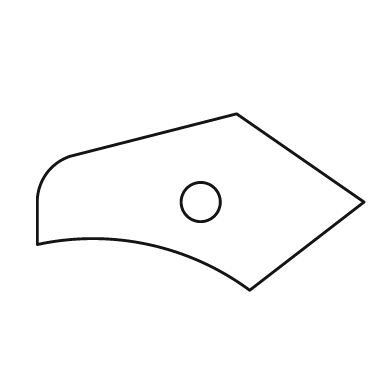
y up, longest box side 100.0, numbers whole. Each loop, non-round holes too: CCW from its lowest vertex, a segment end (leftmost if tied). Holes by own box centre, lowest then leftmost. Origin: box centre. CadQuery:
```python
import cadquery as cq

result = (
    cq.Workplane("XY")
    .moveTo(15.0, -27.0)
    .lineTo(50.0, 0.0)
    .lineTo(11.0, 27.0)
    .lineTo(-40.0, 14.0)
    .threePointArc((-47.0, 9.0), (-50.0, 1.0))
    .lineTo(-50.0, -13.0)
    .threePointArc((-16.0, -13.0), (15.0, -27.0))
    .close()
    .moveTo(0.0, 0.0)
    .circle(6.0)
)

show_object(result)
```